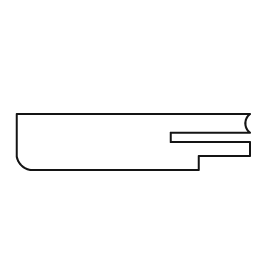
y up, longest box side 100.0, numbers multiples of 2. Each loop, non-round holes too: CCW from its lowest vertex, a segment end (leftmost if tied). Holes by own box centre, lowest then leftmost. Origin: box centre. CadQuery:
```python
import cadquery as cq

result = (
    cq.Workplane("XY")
    .moveTo(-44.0, -12.0)
    .lineTo(28.0, -12.0)
    .lineTo(28.0, -6.0)
    .lineTo(50.0, -6.0)
    .lineTo(50.0, 0.0)
    .lineTo(16.0, 0.0)
    .lineTo(16.0, 4.0)
    .lineTo(50.0, 4.0)
    .threePointArc((48.0, 8.0), (50.0, 12.0))
    .lineTo(-50.0, 12.0)
    .lineTo(-50.0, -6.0)
    .threePointArc((-48.0, -10.0), (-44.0, -12.0))
    .close()
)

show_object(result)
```